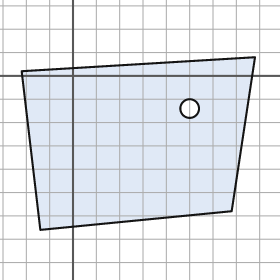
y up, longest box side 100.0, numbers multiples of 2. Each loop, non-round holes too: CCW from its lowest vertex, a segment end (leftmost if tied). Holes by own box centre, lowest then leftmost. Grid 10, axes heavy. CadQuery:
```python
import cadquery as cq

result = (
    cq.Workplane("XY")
    .moveTo(-14.0, -66.0)
    .lineTo(68.0, -58.0)
    .lineTo(78.0, 8.0)
    .lineTo(-22.0, 2.0)
    .close()
    .moveTo(50.0, -14.0)
    .circle(4.0)
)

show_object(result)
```